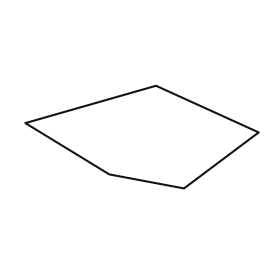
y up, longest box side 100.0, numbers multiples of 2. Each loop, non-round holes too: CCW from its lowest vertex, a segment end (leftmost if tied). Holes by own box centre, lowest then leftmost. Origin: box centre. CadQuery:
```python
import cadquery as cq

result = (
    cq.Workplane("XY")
    .moveTo(18.0, -22.0)
    .lineTo(50.0, 2.0)
    .lineTo(6.0, 22.0)
    .lineTo(-50.0, 6.0)
    .lineTo(-14.0, -16.0)
    .close()
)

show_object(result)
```